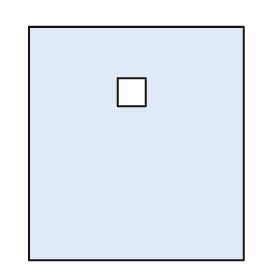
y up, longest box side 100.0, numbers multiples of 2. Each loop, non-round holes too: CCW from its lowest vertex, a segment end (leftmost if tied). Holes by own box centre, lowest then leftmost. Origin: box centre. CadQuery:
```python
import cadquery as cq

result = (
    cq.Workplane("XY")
    .moveTo(-46.0, -50.0)
    .lineTo(46.0, -50.0)
    .lineTo(46.0, 50.0)
    .lineTo(-46.0, 50.0)
    .close()
    .moveTo(-8.0, 16.0)
    .lineTo(4.0, 16.0)
    .lineTo(4.0, 28.0)
    .lineTo(-8.0, 28.0)
    .close()
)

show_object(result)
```